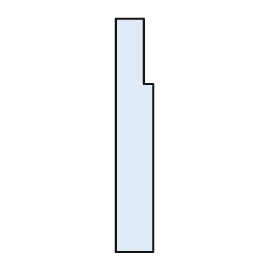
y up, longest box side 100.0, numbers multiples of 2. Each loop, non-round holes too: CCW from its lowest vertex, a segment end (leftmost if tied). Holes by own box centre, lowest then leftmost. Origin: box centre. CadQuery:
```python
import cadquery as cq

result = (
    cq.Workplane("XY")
    .moveTo(-8.0, -50.0)
    .lineTo(8.0, -50.0)
    .lineTo(8.0, 22.0)
    .lineTo(4.0, 22.0)
    .lineTo(4.0, 50.0)
    .lineTo(-8.0, 50.0)
    .close()
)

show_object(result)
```